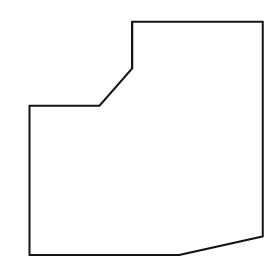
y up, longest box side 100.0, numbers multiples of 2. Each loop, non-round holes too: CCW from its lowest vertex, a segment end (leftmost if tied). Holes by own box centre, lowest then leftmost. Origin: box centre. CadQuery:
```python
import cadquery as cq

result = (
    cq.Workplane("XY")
    .moveTo(-50.0, -50.0)
    .lineTo(14.0, -50.0)
    .lineTo(50.0, -42.0)
    .lineTo(50.0, 50.0)
    .lineTo(-6.0, 50.0)
    .lineTo(-6.0, 30.0)
    .lineTo(-20.0, 14.0)
    .lineTo(-50.0, 14.0)
    .close()
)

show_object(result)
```